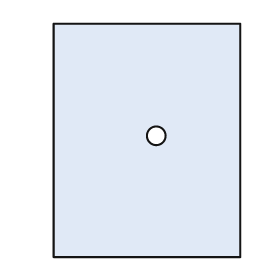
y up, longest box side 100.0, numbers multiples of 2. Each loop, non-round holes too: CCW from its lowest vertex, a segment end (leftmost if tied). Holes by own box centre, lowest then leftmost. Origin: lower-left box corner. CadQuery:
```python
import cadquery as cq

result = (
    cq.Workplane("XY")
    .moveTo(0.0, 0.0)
    .lineTo(80.0, 0.0)
    .lineTo(80.0, 100.0)
    .lineTo(0.0, 100.0)
    .close()
    .moveTo(44.0, 52.0)
    .circle(4.0)
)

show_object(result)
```